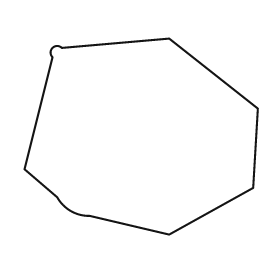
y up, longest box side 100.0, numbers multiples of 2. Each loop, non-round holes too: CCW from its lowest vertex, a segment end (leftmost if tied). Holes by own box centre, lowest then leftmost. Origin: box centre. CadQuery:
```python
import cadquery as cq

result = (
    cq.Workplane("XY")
    .moveTo(12.0, -42.0)
    .lineTo(48.0, -22.0)
    .lineTo(50.0, 12.0)
    .lineTo(12.0, 42.0)
    .lineTo(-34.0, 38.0)
    .threePointArc((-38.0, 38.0), (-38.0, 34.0))
    .lineTo(-50.0, -14.0)
    .lineTo(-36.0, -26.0)
    .threePointArc((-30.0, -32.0), (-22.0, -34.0))
    .close()
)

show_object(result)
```